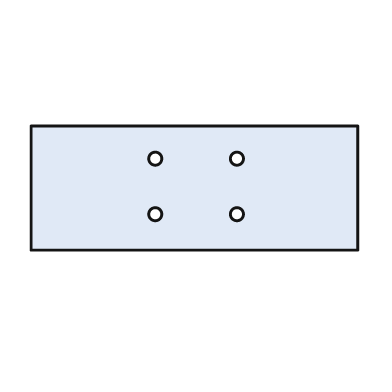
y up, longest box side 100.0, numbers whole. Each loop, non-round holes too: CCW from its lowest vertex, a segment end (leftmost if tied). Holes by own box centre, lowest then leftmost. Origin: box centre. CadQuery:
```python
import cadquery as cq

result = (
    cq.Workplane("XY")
    .moveTo(-50.0, -19.0)
    .lineTo(50.0, -19.0)
    .lineTo(50.0, 19.0)
    .lineTo(-50.0, 19.0)
    .close()
    .moveTo(-12.0, -8.0)
    .circle(2.0)
    .moveTo(13.0, -8.0)
    .circle(2.0)
    .moveTo(-12.0, 9.0)
    .circle(2.0)
    .moveTo(13.0, 9.0)
    .circle(2.0)
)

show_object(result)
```